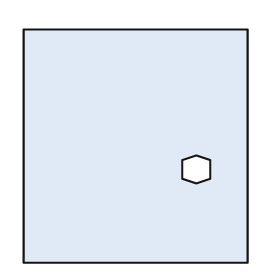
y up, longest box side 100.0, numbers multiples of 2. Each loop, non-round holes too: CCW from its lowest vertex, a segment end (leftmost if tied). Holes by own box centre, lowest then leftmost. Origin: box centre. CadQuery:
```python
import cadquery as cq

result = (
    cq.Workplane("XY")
    .moveTo(-48.0, -50.0)
    .lineTo(48.0, -50.0)
    .lineTo(48.0, 50.0)
    .lineTo(-48.0, 50.0)
    .close()
    .moveTo(26.0, -16.0)
    .lineTo(32.0, -14.0)
    .lineTo(32.0, -6.0)
    .lineTo(26.0, -4.0)
    .lineTo(20.0, -6.0)
    .lineTo(20.0, -14.0)
    .close()
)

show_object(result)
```